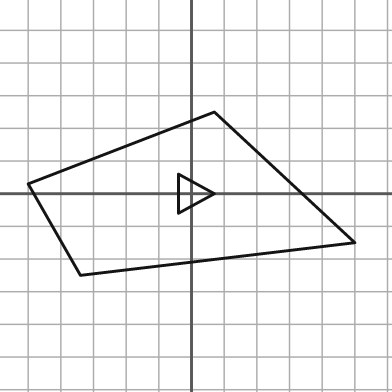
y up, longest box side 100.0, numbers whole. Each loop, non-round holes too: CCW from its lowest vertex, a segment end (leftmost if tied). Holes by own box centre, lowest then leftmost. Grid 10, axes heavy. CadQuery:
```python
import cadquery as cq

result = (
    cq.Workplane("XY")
    .moveTo(-34.0, -25.0)
    .lineTo(50.0, -15.0)
    .lineTo(7.0, 25.0)
    .lineTo(-50.0, 3.0)
    .close()
    .moveTo(-4.0, -6.0)
    .lineTo(7.0, 0.0)
    .lineTo(-4.0, 6.0)
    .close()
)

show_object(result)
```